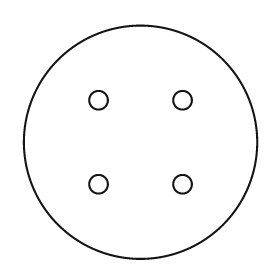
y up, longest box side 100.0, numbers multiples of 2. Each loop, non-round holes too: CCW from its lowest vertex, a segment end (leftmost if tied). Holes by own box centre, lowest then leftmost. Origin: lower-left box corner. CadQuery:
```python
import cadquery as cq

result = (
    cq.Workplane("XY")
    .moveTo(50.0, 50.0)
    .circle(50.0)
    .moveTo(32.0, 32.0)
    .circle(4.0)
    .moveTo(68.0, 32.0)
    .circle(4.0)
    .moveTo(32.0, 68.0)
    .circle(4.0)
    .moveTo(68.0, 68.0)
    .circle(4.0)
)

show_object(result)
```